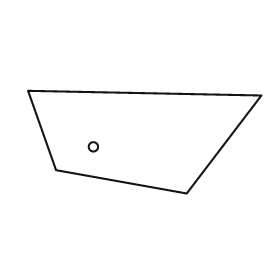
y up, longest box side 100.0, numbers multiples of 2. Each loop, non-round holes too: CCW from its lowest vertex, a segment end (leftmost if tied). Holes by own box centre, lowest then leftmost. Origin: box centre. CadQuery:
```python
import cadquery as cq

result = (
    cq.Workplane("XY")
    .moveTo(18.0, -22.0)
    .lineTo(50.0, 20.0)
    .lineTo(-50.0, 22.0)
    .lineTo(-38.0, -12.0)
    .close()
    .moveTo(-22.0, -2.0)
    .circle(2.0)
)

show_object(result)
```